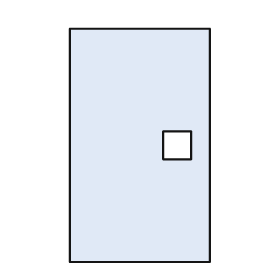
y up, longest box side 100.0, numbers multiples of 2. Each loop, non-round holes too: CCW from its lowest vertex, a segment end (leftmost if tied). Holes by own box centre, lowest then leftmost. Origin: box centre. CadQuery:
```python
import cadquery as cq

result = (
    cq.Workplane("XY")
    .moveTo(-30.0, -50.0)
    .lineTo(30.0, -50.0)
    .lineTo(30.0, 50.0)
    .lineTo(-30.0, 50.0)
    .close()
    .moveTo(10.0, -6.0)
    .lineTo(22.0, -6.0)
    .lineTo(22.0, 6.0)
    .lineTo(10.0, 6.0)
    .close()
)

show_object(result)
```